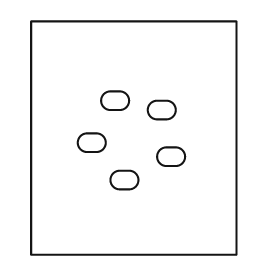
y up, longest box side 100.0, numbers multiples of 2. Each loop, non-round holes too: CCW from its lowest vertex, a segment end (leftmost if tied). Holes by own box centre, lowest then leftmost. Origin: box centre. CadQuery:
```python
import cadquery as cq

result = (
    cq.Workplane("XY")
    .moveTo(-44.0, -50.0)
    .lineTo(44.0, -50.0)
    .lineTo(44.0, 50.0)
    .lineTo(-44.0, 50.0)
    .close()
    .moveTo(-6.0, -22.0)
    .lineTo(-2.0, -22.0)
    .threePointArc((2.0, -18.0), (-2.0, -14.0))
    .lineTo(-6.0, -14.0)
    .threePointArc((-10.0, -18.0), (-6.0, -22.0))
    .close()
    .moveTo(14.0, -12.0)
    .lineTo(18.0, -12.0)
    .threePointArc((22.0, -8.0), (18.0, -4.0))
    .lineTo(14.0, -4.0)
    .threePointArc((10.0, -8.0), (14.0, -12.0))
    .close()
    .moveTo(-20.0, -6.0)
    .lineTo(-16.0, -6.0)
    .threePointArc((-12.0, -2.0), (-16.0, 2.0))
    .lineTo(-20.0, 2.0)
    .threePointArc((-24.0, -2.0), (-20.0, -6.0))
    .close()
    .moveTo(10.0, 8.0)
    .lineTo(14.0, 8.0)
    .threePointArc((18.0, 12.0), (14.0, 16.0))
    .lineTo(10.0, 16.0)
    .threePointArc((6.0, 12.0), (10.0, 8.0))
    .close()
    .moveTo(-10.0, 12.0)
    .lineTo(-6.0, 12.0)
    .threePointArc((-2.0, 16.0), (-6.0, 20.0))
    .lineTo(-10.0, 20.0)
    .threePointArc((-14.0, 16.0), (-10.0, 12.0))
    .close()
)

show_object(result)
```